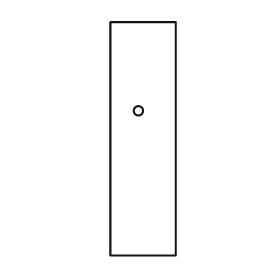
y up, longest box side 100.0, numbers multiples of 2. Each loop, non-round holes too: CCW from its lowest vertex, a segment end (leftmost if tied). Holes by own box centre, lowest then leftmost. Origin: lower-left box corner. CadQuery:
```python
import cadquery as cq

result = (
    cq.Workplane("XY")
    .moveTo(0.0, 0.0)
    .lineTo(28.0, 0.0)
    .lineTo(28.0, 100.0)
    .lineTo(0.0, 100.0)
    .close()
    .moveTo(12.0, 62.0)
    .circle(2.0)
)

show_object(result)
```